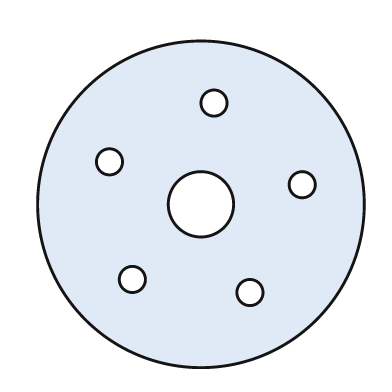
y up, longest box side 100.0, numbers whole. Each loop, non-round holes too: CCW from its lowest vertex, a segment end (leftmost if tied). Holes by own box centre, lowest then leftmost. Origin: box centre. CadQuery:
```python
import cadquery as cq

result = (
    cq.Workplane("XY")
    .moveTo(0.0, 0.0)
    .circle(50.0)
    .moveTo(15.0, -27.0)
    .circle(4.0)
    .moveTo(-21.0, -23.0)
    .circle(4.0)
    .moveTo(0.0, 0.0)
    .circle(10.0)
    .moveTo(31.0, 6.0)
    .circle(4.0)
    .moveTo(-28.0, 13.0)
    .circle(4.0)
    .moveTo(4.0, 31.0)
    .circle(4.0)
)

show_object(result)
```